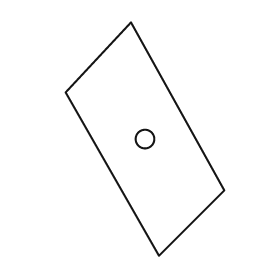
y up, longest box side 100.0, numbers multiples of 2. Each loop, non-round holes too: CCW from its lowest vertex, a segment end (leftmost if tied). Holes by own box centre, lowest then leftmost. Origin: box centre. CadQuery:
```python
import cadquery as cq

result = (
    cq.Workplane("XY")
    .moveTo(6.0, -50.0)
    .lineTo(34.0, -22.0)
    .lineTo(-6.0, 50.0)
    .lineTo(-34.0, 20.0)
    .close()
    .moveTo(0.0, 0.0)
    .circle(4.0)
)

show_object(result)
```